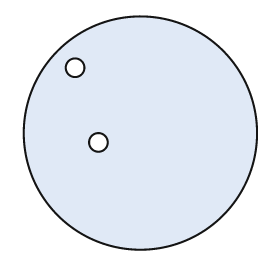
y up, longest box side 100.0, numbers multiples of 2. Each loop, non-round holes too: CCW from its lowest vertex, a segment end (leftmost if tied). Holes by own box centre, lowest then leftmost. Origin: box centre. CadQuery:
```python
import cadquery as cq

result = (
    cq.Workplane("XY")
    .moveTo(0.0, 0.0)
    .circle(50.0)
    .moveTo(-18.0, -4.0)
    .circle(4.0)
    .moveTo(-28.0, 28.0)
    .circle(4.0)
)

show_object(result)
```